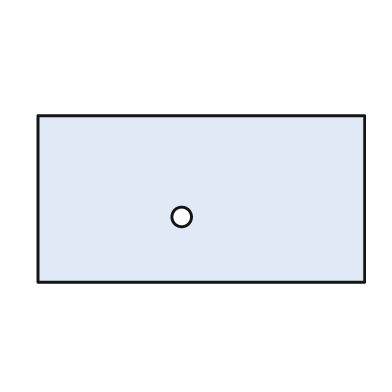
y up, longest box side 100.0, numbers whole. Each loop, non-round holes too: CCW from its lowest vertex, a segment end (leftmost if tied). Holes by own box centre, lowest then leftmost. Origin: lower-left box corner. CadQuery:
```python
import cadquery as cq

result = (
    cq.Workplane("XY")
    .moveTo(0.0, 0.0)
    .lineTo(100.0, 0.0)
    .lineTo(100.0, 51.0)
    .lineTo(0.0, 51.0)
    .close()
    .moveTo(44.0, 20.0)
    .circle(3.0)
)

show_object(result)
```